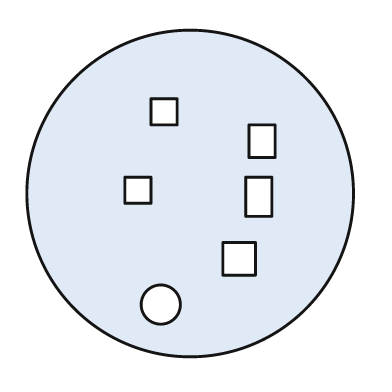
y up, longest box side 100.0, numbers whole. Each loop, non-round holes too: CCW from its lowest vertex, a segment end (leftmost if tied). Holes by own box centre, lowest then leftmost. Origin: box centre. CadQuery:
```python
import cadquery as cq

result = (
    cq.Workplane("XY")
    .moveTo(0.0, 0.0)
    .circle(50.0)
    .moveTo(-9.0, -34.0)
    .circle(6.0)
    .moveTo(10.0, -25.0)
    .lineTo(20.0, -25.0)
    .lineTo(20.0, -15.0)
    .lineTo(10.0, -15.0)
    .close()
    .moveTo(17.0, -7.0)
    .lineTo(25.0, -7.0)
    .lineTo(25.0, 5.0)
    .lineTo(17.0, 5.0)
    .close()
    .moveTo(-20.0, -3.0)
    .lineTo(-12.0, -3.0)
    .lineTo(-12.0, 5.0)
    .lineTo(-20.0, 5.0)
    .close()
    .moveTo(18.0, 11.0)
    .lineTo(26.0, 11.0)
    .lineTo(26.0, 21.0)
    .lineTo(18.0, 21.0)
    .close()
    .moveTo(-12.0, 21.0)
    .lineTo(-4.0, 21.0)
    .lineTo(-4.0, 29.0)
    .lineTo(-12.0, 29.0)
    .close()
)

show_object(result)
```